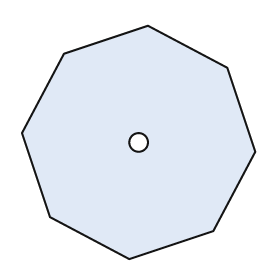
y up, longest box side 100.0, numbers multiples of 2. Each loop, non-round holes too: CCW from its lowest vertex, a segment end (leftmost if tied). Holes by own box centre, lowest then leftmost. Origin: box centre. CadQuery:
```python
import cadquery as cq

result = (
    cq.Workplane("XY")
    .moveTo(-4.0, -50.0)
    .lineTo(32.0, -38.0)
    .lineTo(50.0, -4.0)
    .lineTo(38.0, 32.0)
    .lineTo(4.0, 50.0)
    .lineTo(-32.0, 38.0)
    .lineTo(-50.0, 4.0)
    .lineTo(-38.0, -32.0)
    .close()
    .moveTo(0.0, 0.0)
    .circle(4.0)
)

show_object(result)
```